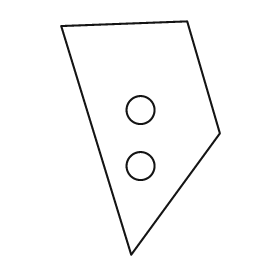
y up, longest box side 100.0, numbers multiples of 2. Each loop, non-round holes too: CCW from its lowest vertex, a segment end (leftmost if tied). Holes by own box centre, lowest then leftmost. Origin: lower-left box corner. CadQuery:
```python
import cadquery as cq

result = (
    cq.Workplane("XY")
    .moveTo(30.0, 0.0)
    .lineTo(68.0, 52.0)
    .lineTo(54.0, 100.0)
    .lineTo(0.0, 98.0)
    .close()
    .moveTo(34.0, 38.0)
    .circle(6.0)
    .moveTo(34.0, 62.0)
    .circle(6.0)
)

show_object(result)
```